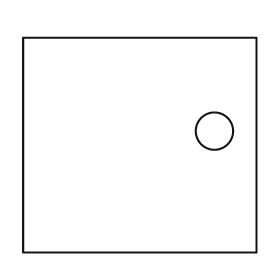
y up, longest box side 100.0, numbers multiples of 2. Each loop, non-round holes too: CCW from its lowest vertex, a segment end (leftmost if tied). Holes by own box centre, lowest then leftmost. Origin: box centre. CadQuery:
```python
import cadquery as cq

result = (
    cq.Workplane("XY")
    .moveTo(-50.0, -46.0)
    .lineTo(50.0, -46.0)
    .lineTo(50.0, 46.0)
    .lineTo(-50.0, 46.0)
    .close()
    .moveTo(32.0, 6.0)
    .circle(8.0)
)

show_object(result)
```